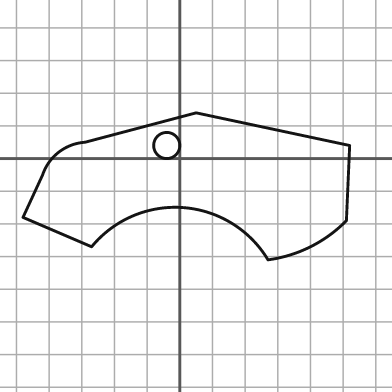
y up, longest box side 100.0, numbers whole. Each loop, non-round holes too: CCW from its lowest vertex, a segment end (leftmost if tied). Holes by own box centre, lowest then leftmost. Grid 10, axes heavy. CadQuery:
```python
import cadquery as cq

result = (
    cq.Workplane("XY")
    .moveTo(27.0, -31.0)
    .threePointArc((40.0, -27.0), (51.0, -19.0))
    .lineTo(52.0, 4.0)
    .lineTo(5.0, 14.0)
    .lineTo(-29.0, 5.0)
    .threePointArc((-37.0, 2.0), (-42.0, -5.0))
    .lineTo(-48.0, -18.0)
    .lineTo(-27.0, -27.0)
    .threePointArc((1.0, -15.0), (27.0, -31.0))
    .close()
    .moveTo(-4.0, 4.0)
    .circle(4.0)
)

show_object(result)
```